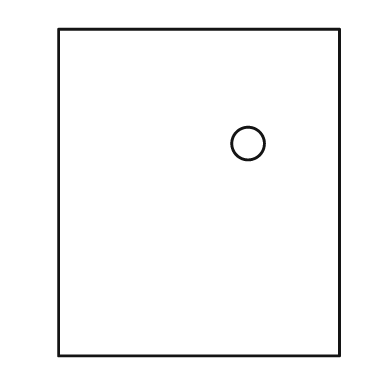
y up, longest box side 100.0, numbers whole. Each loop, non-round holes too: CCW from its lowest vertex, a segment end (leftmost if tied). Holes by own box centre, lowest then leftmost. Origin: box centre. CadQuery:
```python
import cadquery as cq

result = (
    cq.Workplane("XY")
    .moveTo(-43.0, -50.0)
    .lineTo(43.0, -50.0)
    .lineTo(43.0, 50.0)
    .lineTo(-43.0, 50.0)
    .close()
    .moveTo(15.0, 15.0)
    .circle(5.0)
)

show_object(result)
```